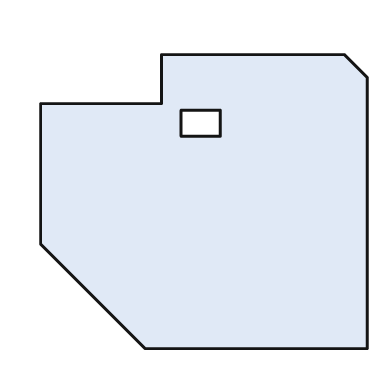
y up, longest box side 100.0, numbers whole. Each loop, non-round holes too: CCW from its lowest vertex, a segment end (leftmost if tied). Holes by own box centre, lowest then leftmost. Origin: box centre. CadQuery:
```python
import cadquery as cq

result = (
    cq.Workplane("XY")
    .moveTo(-18.0, -45.0)
    .lineTo(50.0, -45.0)
    .lineTo(50.0, 38.0)
    .lineTo(43.0, 45.0)
    .lineTo(-13.0, 45.0)
    .lineTo(-13.0, 30.0)
    .lineTo(-50.0, 30.0)
    .lineTo(-50.0, -13.0)
    .close()
    .moveTo(-7.0, 20.0)
    .lineTo(5.0, 20.0)
    .lineTo(5.0, 28.0)
    .lineTo(-7.0, 28.0)
    .close()
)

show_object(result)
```